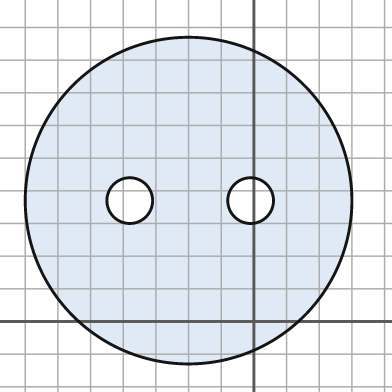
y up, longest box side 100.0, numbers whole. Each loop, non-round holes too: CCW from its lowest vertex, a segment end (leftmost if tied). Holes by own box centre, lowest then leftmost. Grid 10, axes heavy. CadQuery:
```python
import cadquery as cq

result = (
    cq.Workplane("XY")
    .moveTo(-20.0, 37.0)
    .circle(50.0)
    .moveTo(-38.0, 37.0)
    .circle(7.0)
    .moveTo(-1.0, 37.0)
    .circle(7.0)
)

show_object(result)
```